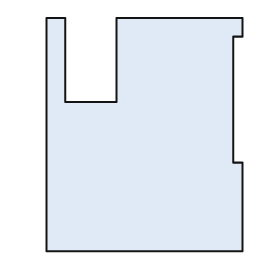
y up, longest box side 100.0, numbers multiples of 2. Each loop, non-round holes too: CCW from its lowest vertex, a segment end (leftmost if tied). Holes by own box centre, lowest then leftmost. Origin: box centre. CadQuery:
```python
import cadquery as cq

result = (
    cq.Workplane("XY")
    .moveTo(-42.0, -50.0)
    .lineTo(42.0, -50.0)
    .lineTo(42.0, -12.0)
    .lineTo(38.0, -12.0)
    .lineTo(38.0, 42.0)
    .lineTo(42.0, 42.0)
    .lineTo(42.0, 50.0)
    .lineTo(-12.0, 50.0)
    .lineTo(-12.0, 14.0)
    .lineTo(-34.0, 14.0)
    .lineTo(-34.0, 50.0)
    .lineTo(-42.0, 50.0)
    .close()
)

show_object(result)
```